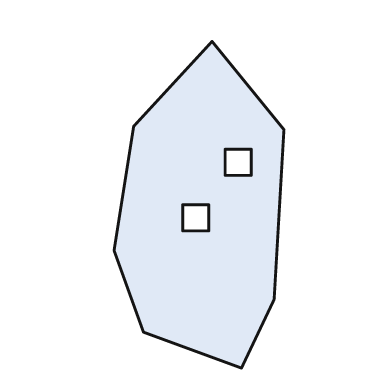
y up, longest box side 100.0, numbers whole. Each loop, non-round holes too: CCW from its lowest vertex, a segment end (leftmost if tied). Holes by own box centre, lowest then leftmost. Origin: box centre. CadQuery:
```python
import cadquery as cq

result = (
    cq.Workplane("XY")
    .moveTo(13.0, -50.0)
    .lineTo(23.0, -29.0)
    .lineTo(26.0, 23.0)
    .lineTo(4.0, 50.0)
    .lineTo(-20.0, 24.0)
    .lineTo(-26.0, -14.0)
    .lineTo(-17.0, -39.0)
    .close()
    .moveTo(-5.0, -8.0)
    .lineTo(3.0, -8.0)
    .lineTo(3.0, 0.0)
    .lineTo(-5.0, 0.0)
    .close()
    .moveTo(8.0, 9.0)
    .lineTo(16.0, 9.0)
    .lineTo(16.0, 17.0)
    .lineTo(8.0, 17.0)
    .close()
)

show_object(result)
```